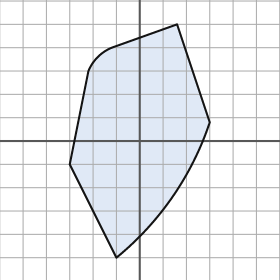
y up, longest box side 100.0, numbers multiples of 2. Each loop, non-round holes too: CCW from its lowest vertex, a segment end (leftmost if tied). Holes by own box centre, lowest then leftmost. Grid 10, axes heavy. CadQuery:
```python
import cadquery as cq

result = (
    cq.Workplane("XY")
    .moveTo(-10.0, -50.0)
    .threePointArc((14.0, -24.0), (30.0, 8.0))
    .lineTo(16.0, 50.0)
    .lineTo(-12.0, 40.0)
    .threePointArc((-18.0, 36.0), (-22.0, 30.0))
    .lineTo(-30.0, -10.0)
    .close()
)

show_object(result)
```